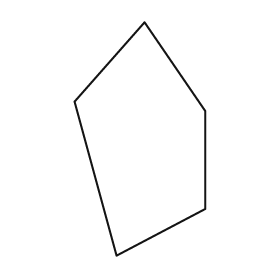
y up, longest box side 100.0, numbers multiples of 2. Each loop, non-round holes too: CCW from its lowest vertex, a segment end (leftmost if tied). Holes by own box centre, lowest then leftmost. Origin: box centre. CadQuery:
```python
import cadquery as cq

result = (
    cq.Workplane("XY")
    .moveTo(-10.0, -50.0)
    .lineTo(28.0, -30.0)
    .lineTo(28.0, 12.0)
    .lineTo(2.0, 50.0)
    .lineTo(-28.0, 16.0)
    .close()
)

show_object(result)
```